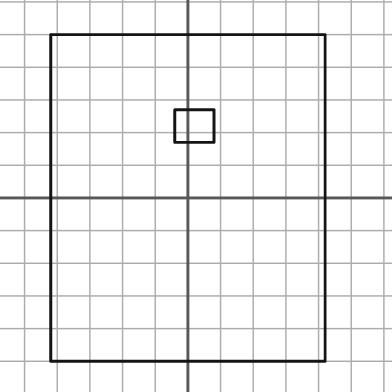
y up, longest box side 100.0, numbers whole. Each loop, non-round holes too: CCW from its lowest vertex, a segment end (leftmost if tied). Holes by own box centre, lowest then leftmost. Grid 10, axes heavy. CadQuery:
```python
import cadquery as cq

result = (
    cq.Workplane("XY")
    .moveTo(-42.0, -50.0)
    .lineTo(42.0, -50.0)
    .lineTo(42.0, 50.0)
    .lineTo(-42.0, 50.0)
    .close()
    .moveTo(-4.0, 17.0)
    .lineTo(8.0, 17.0)
    .lineTo(8.0, 27.0)
    .lineTo(-4.0, 27.0)
    .close()
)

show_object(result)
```